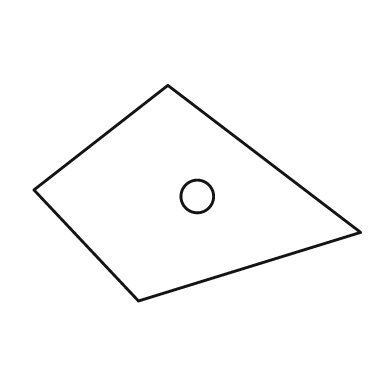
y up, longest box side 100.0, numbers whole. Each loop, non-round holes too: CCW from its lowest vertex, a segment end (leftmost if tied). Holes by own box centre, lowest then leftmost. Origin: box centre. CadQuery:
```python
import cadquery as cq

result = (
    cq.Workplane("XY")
    .moveTo(-18.0, -33.0)
    .lineTo(50.0, -12.0)
    .lineTo(-9.0, 33.0)
    .lineTo(-50.0, 1.0)
    .close()
    .moveTo(0.0, -1.0)
    .circle(5.0)
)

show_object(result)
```